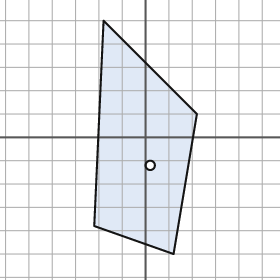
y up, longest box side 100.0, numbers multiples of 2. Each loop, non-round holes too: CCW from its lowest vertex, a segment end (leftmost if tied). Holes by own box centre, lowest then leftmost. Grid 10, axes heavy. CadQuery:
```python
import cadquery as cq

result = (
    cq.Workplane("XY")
    .moveTo(12.0, -50.0)
    .lineTo(22.0, 10.0)
    .lineTo(-18.0, 50.0)
    .lineTo(-22.0, -38.0)
    .close()
    .moveTo(2.0, -12.0)
    .circle(2.0)
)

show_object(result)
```